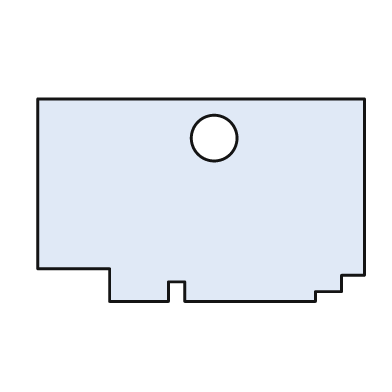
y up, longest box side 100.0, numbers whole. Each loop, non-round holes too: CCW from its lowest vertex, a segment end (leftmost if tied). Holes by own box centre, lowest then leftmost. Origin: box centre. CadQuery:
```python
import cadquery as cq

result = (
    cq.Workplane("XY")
    .moveTo(-28.0, -31.0)
    .lineTo(-10.0, -31.0)
    .lineTo(-10.0, -25.0)
    .lineTo(-5.0, -25.0)
    .lineTo(-5.0, -31.0)
    .lineTo(35.0, -31.0)
    .lineTo(35.0, -28.0)
    .lineTo(43.0, -28.0)
    .lineTo(43.0, -23.0)
    .lineTo(50.0, -23.0)
    .lineTo(50.0, 31.0)
    .lineTo(-50.0, 31.0)
    .lineTo(-50.0, -21.0)
    .lineTo(-28.0, -21.0)
    .close()
    .moveTo(4.0, 19.0)
    .circle(7.0)
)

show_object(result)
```